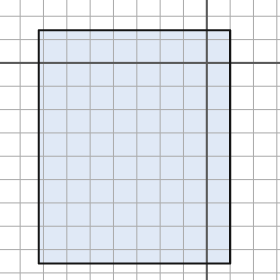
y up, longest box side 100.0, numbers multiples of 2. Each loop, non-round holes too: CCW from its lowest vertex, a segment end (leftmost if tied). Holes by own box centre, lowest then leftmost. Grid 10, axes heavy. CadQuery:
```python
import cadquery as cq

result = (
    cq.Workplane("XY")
    .moveTo(-72.0, -86.0)
    .lineTo(10.0, -86.0)
    .lineTo(10.0, 14.0)
    .lineTo(-72.0, 14.0)
    .close()
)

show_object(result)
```